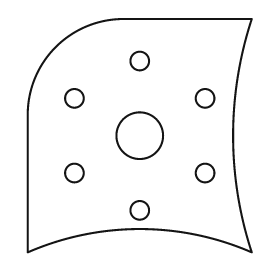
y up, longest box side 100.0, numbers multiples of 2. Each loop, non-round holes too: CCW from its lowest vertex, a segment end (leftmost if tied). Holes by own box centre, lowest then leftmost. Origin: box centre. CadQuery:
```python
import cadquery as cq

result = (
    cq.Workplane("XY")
    .moveTo(-48.0, -50.0)
    .threePointArc((0.0, -40.0), (48.0, -50.0))
    .threePointArc((40.0, 0.0), (48.0, 50.0))
    .lineTo(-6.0, 50.0)
    .threePointArc((-36.0, 38.0), (-48.0, 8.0))
    .close()
    .moveTo(0.0, -32.0)
    .circle(4.0)
    .moveTo(-28.0, -16.0)
    .circle(4.0)
    .moveTo(28.0, -16.0)
    .circle(4.0)
    .moveTo(0.0, 0.0)
    .circle(10.0)
    .moveTo(-28.0, 16.0)
    .circle(4.0)
    .moveTo(28.0, 16.0)
    .circle(4.0)
    .moveTo(0.0, 32.0)
    .circle(4.0)
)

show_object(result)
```